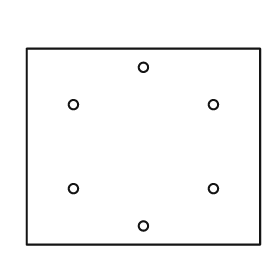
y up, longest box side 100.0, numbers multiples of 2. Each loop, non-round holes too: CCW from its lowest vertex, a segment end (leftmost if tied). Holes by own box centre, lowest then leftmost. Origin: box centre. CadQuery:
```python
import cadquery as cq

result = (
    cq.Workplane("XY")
    .moveTo(-50.0, -42.0)
    .lineTo(50.0, -42.0)
    .lineTo(50.0, 42.0)
    .lineTo(-50.0, 42.0)
    .close()
    .moveTo(0.0, -34.0)
    .circle(2.0)
    .moveTo(-30.0, -18.0)
    .circle(2.0)
    .moveTo(30.0, -18.0)
    .circle(2.0)
    .moveTo(-30.0, 18.0)
    .circle(2.0)
    .moveTo(30.0, 18.0)
    .circle(2.0)
    .moveTo(0.0, 34.0)
    .circle(2.0)
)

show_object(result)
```